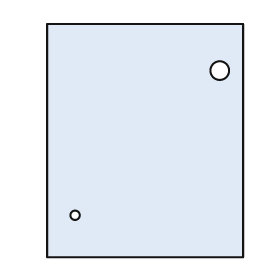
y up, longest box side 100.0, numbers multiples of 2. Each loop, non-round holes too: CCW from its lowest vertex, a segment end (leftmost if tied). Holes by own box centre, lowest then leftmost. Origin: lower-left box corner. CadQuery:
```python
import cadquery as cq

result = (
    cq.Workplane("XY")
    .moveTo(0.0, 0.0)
    .lineTo(84.0, 0.0)
    .lineTo(84.0, 100.0)
    .lineTo(0.0, 100.0)
    .close()
    .moveTo(12.0, 18.0)
    .circle(2.0)
    .moveTo(74.0, 80.0)
    .circle(4.0)
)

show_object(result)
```